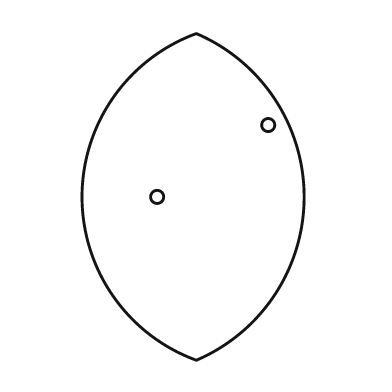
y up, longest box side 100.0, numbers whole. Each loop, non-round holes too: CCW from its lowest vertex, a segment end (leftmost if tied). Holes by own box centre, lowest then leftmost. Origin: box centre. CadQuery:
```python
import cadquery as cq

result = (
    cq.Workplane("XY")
    .moveTo(1.0, -50.0)
    .threePointArc((34.0, 0.0), (1.0, 50.0))
    .threePointArc((-34.0, 0.0), (1.0, -50.0))
    .close()
    .moveTo(-11.0, 0.0)
    .circle(2.0)
    .moveTo(23.0, 22.0)
    .circle(2.0)
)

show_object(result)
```